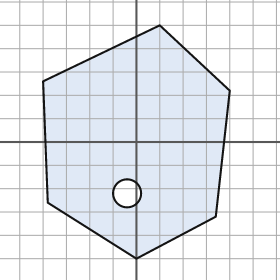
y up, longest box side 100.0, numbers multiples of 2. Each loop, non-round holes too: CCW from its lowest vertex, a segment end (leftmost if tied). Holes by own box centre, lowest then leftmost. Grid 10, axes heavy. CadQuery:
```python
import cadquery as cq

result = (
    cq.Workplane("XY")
    .moveTo(0.0, -50.0)
    .lineTo(34.0, -32.0)
    .lineTo(40.0, 22.0)
    .lineTo(10.0, 50.0)
    .lineTo(-40.0, 26.0)
    .lineTo(-38.0, -26.0)
    .close()
    .moveTo(-4.0, -22.0)
    .circle(6.0)
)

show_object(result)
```